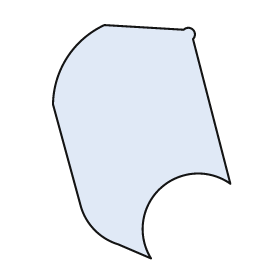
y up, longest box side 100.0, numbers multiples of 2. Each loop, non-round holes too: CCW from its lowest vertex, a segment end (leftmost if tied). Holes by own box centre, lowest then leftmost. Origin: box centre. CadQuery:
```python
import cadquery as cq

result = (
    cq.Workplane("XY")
    .moveTo(4.0, -50.0)
    .threePointArc((8.0, -20.0), (38.0, -18.0))
    .lineTo(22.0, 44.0)
    .threePointArc((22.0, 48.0), (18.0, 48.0))
    .lineTo(-16.0, 50.0)
    .threePointArc((-32.0, 36.0), (-38.0, 16.0))
    .lineTo(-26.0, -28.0)
    .threePointArc((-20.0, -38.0), (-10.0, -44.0))
    .close()
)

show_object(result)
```